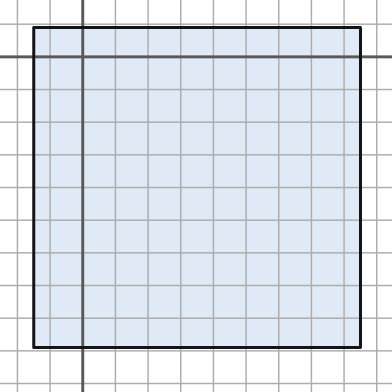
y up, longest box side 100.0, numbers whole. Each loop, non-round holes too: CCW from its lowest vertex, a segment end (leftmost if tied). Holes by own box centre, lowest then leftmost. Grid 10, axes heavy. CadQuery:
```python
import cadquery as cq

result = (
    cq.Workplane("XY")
    .moveTo(-15.0, -89.0)
    .lineTo(85.0, -89.0)
    .lineTo(85.0, 9.0)
    .lineTo(-15.0, 9.0)
    .close()
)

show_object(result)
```